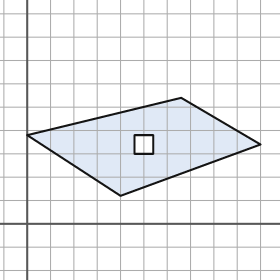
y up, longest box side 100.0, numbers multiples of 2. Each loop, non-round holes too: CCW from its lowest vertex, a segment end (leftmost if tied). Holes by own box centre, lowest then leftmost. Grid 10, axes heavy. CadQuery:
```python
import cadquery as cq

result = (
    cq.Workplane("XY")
    .moveTo(40.0, 12.0)
    .lineTo(100.0, 34.0)
    .lineTo(66.0, 54.0)
    .lineTo(0.0, 38.0)
    .close()
    .moveTo(46.0, 30.0)
    .lineTo(54.0, 30.0)
    .lineTo(54.0, 38.0)
    .lineTo(46.0, 38.0)
    .close()
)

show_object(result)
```